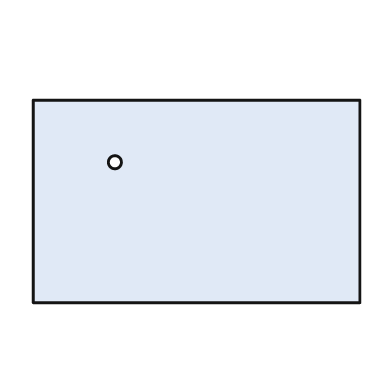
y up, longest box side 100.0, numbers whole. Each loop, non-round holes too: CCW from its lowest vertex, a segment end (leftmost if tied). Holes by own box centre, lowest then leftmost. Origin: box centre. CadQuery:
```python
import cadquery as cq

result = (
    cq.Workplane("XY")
    .moveTo(-50.0, -31.0)
    .lineTo(50.0, -31.0)
    .lineTo(50.0, 31.0)
    .lineTo(-50.0, 31.0)
    .close()
    .moveTo(-25.0, 12.0)
    .circle(2.0)
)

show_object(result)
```